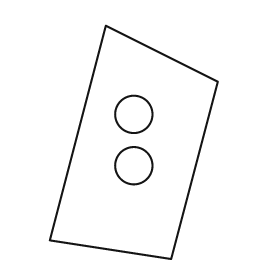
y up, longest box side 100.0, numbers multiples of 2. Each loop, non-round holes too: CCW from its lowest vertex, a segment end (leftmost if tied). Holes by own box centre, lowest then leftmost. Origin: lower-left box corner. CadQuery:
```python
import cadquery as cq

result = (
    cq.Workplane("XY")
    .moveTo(52.0, 0.0)
    .lineTo(72.0, 76.0)
    .lineTo(24.0, 100.0)
    .lineTo(0.0, 8.0)
    .close()
    .moveTo(36.0, 40.0)
    .circle(8.0)
    .moveTo(36.0, 62.0)
    .circle(8.0)
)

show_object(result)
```